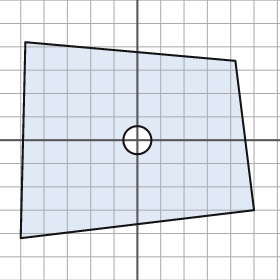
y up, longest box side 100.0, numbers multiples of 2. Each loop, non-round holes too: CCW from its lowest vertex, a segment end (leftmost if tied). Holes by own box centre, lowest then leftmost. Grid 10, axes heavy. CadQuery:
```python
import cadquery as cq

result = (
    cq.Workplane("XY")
    .moveTo(-50.0, -42.0)
    .lineTo(50.0, -30.0)
    .lineTo(42.0, 34.0)
    .lineTo(-48.0, 42.0)
    .close()
    .moveTo(0.0, 0.0)
    .circle(6.0)
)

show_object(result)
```